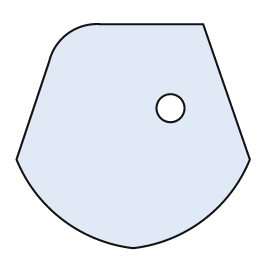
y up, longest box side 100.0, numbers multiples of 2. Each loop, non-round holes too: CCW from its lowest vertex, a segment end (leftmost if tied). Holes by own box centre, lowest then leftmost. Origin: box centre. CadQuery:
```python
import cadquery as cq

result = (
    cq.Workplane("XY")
    .moveTo(0.0, -48.0)
    .threePointArc((30.0, -36.0), (50.0, -10.0))
    .lineTo(30.0, 48.0)
    .lineTo(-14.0, 48.0)
    .threePointArc((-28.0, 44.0), (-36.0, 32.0))
    .lineTo(-50.0, -10.0)
    .threePointArc((-30.0, -36.0), (0.0, -48.0))
    .close()
    .moveTo(16.0, 12.0)
    .circle(6.0)
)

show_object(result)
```